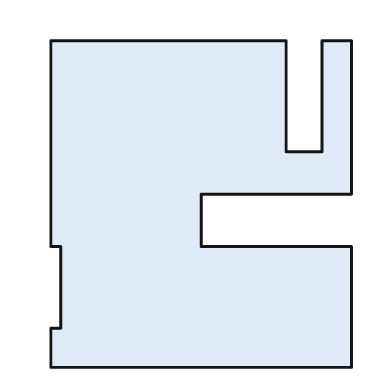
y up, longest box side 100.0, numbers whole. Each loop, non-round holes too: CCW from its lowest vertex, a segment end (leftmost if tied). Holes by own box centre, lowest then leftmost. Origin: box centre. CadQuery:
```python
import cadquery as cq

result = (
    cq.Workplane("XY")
    .moveTo(-46.0, -50.0)
    .lineTo(46.0, -50.0)
    .lineTo(46.0, -13.0)
    .lineTo(0.0, -13.0)
    .lineTo(0.0, 3.0)
    .lineTo(46.0, 3.0)
    .lineTo(46.0, 50.0)
    .lineTo(37.0, 50.0)
    .lineTo(37.0, 16.0)
    .lineTo(26.0, 16.0)
    .lineTo(26.0, 50.0)
    .lineTo(-46.0, 50.0)
    .lineTo(-46.0, -13.0)
    .lineTo(-43.0, -13.0)
    .lineTo(-43.0, -38.0)
    .lineTo(-46.0, -38.0)
    .close()
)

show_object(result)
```